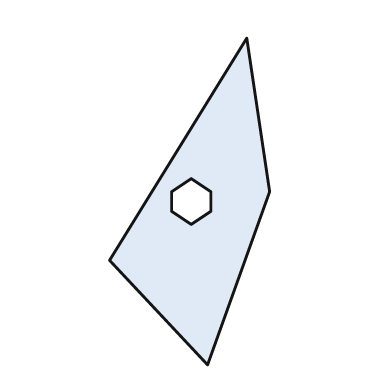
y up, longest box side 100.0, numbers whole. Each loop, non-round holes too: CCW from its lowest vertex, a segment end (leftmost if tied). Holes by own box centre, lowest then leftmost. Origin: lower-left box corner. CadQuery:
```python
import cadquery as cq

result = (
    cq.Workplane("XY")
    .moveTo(30.0, 0.0)
    .lineTo(49.0, 53.0)
    .lineTo(42.0, 100.0)
    .lineTo(0.0, 32.0)
    .close()
    .moveTo(25.0, 43.0)
    .lineTo(31.0, 47.0)
    .lineTo(31.0, 53.0)
    .lineTo(25.0, 57.0)
    .lineTo(19.0, 53.0)
    .lineTo(19.0, 47.0)
    .close()
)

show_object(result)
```